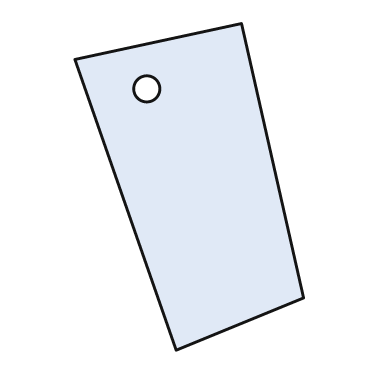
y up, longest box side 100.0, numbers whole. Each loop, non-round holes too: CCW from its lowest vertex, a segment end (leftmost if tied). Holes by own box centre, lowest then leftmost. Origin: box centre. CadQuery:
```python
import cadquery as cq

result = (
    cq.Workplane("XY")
    .moveTo(-4.0, -50.0)
    .lineTo(35.0, -34.0)
    .lineTo(16.0, 50.0)
    .lineTo(-35.0, 39.0)
    .close()
    .moveTo(-13.0, 30.0)
    .circle(4.0)
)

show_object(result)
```